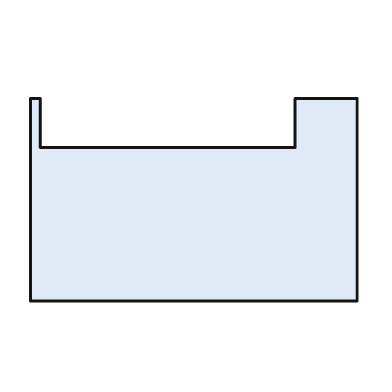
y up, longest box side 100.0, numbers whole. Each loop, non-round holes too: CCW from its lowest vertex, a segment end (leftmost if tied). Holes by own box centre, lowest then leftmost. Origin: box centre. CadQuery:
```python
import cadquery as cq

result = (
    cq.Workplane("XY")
    .moveTo(-50.0, -31.0)
    .lineTo(50.0, -31.0)
    .lineTo(50.0, 31.0)
    .lineTo(31.0, 31.0)
    .lineTo(31.0, 16.0)
    .lineTo(-47.0, 16.0)
    .lineTo(-47.0, 31.0)
    .lineTo(-50.0, 31.0)
    .close()
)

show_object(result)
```